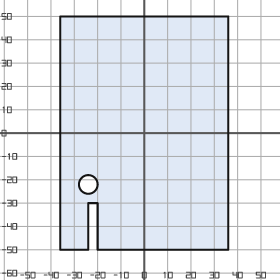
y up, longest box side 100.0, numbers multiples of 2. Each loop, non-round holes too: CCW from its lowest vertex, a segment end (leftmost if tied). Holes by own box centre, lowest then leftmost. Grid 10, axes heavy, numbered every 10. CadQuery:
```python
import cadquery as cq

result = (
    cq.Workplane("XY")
    .moveTo(-36.0, -50.0)
    .lineTo(-24.0, -50.0)
    .lineTo(-24.0, -30.0)
    .lineTo(-20.0, -30.0)
    .lineTo(-20.0, -50.0)
    .lineTo(36.0, -50.0)
    .lineTo(36.0, 50.0)
    .lineTo(-36.0, 50.0)
    .close()
    .moveTo(-24.0, -22.0)
    .circle(4.0)
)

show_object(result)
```